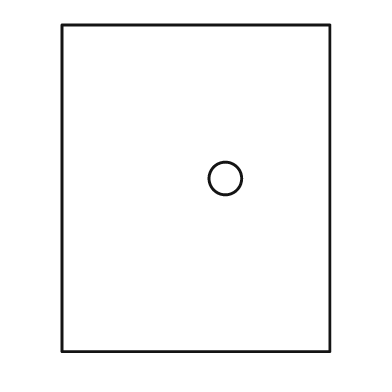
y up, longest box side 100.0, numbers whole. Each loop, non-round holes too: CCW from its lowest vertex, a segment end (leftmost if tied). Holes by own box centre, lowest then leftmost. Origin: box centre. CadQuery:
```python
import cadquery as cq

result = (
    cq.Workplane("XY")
    .moveTo(-41.0, -50.0)
    .lineTo(41.0, -50.0)
    .lineTo(41.0, 50.0)
    .lineTo(-41.0, 50.0)
    .close()
    .moveTo(9.0, 3.0)
    .circle(5.0)
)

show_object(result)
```